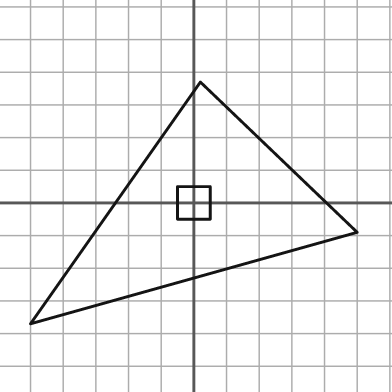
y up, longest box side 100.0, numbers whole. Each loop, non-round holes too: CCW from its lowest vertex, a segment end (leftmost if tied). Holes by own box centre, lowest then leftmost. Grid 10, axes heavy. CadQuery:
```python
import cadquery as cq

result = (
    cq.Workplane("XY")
    .moveTo(-50.0, -37.0)
    .lineTo(50.0, -9.0)
    .lineTo(2.0, 37.0)
    .close()
    .moveTo(-5.0, -5.0)
    .lineTo(5.0, -5.0)
    .lineTo(5.0, 5.0)
    .lineTo(-5.0, 5.0)
    .close()
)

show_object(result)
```